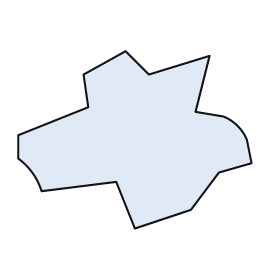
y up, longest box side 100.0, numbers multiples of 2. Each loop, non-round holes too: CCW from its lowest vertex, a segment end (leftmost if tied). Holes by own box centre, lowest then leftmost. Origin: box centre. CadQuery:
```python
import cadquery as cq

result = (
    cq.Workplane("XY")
    .moveTo(0.0, -38.0)
    .lineTo(24.0, -30.0)
    .lineTo(36.0, -14.0)
    .lineTo(50.0, -10.0)
    .lineTo(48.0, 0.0)
    .threePointArc((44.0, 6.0), (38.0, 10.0))
    .lineTo(26.0, 12.0)
    .lineTo(32.0, 36.0)
    .lineTo(6.0, 28.0)
    .lineTo(-4.0, 38.0)
    .lineTo(-22.0, 28.0)
    .lineTo(-20.0, 14.0)
    .lineTo(-50.0, 2.0)
    .lineTo(-50.0, -8.0)
    .threePointArc((-44.0, -14.0), (-40.0, -22.0))
    .lineTo(-8.0, -18.0)
    .close()
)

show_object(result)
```